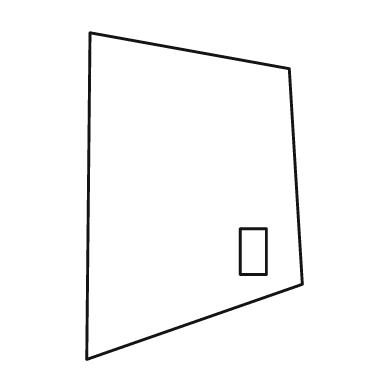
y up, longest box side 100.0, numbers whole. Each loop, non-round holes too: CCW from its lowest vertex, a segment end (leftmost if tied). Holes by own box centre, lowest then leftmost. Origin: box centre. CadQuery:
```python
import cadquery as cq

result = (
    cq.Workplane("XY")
    .moveTo(-33.0, -50.0)
    .lineTo(33.0, -27.0)
    .lineTo(29.0, 39.0)
    .lineTo(-32.0, 50.0)
    .close()
    .moveTo(14.0, -24.0)
    .lineTo(22.0, -24.0)
    .lineTo(22.0, -10.0)
    .lineTo(14.0, -10.0)
    .close()
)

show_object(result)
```